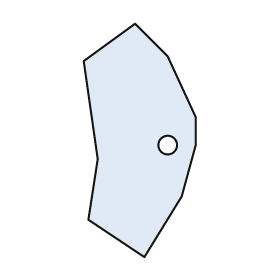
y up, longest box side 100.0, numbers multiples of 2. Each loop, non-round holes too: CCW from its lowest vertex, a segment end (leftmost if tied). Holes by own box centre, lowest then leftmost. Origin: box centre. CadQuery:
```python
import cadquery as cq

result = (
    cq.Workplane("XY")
    .moveTo(2.0, -50.0)
    .lineTo(18.0, -24.0)
    .lineTo(24.0, -2.0)
    .lineTo(24.0, 10.0)
    .lineTo(12.0, 36.0)
    .lineTo(-2.0, 50.0)
    .lineTo(-24.0, 34.0)
    .lineTo(-18.0, -8.0)
    .lineTo(-22.0, -34.0)
    .close()
    .moveTo(12.0, -2.0)
    .circle(4.0)
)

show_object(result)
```